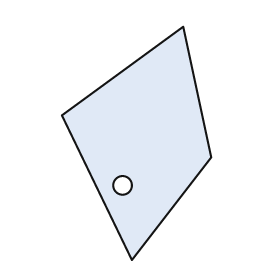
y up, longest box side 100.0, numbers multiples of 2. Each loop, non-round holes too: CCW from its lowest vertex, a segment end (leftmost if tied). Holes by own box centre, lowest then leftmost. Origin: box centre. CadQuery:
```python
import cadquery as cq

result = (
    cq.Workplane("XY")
    .moveTo(-2.0, -50.0)
    .lineTo(32.0, -6.0)
    .lineTo(20.0, 50.0)
    .lineTo(-32.0, 12.0)
    .close()
    .moveTo(-6.0, -18.0)
    .circle(4.0)
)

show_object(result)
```